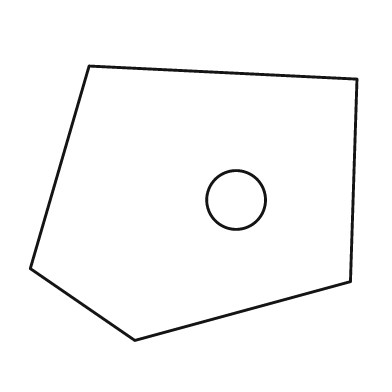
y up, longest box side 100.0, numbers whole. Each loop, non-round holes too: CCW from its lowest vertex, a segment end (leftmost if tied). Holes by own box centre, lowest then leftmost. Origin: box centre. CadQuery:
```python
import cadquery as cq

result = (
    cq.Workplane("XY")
    .moveTo(-18.0, -42.0)
    .lineTo(48.0, -24.0)
    .lineTo(50.0, 38.0)
    .lineTo(-32.0, 42.0)
    .lineTo(-50.0, -20.0)
    .close()
    .moveTo(13.0, 1.0)
    .circle(9.0)
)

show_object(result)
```